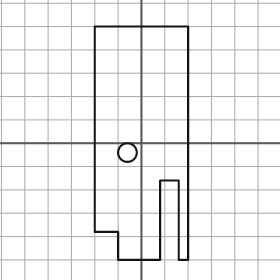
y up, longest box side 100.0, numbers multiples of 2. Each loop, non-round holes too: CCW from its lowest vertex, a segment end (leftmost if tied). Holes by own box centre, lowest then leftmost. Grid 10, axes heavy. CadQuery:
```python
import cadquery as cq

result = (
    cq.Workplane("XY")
    .moveTo(-10.0, -50.0)
    .lineTo(8.0, -50.0)
    .lineTo(8.0, -16.0)
    .lineTo(16.0, -16.0)
    .lineTo(16.0, -50.0)
    .lineTo(20.0, -50.0)
    .lineTo(20.0, 50.0)
    .lineTo(-20.0, 50.0)
    .lineTo(-20.0, -38.0)
    .lineTo(-10.0, -38.0)
    .close()
    .moveTo(-6.0, -4.0)
    .circle(4.0)
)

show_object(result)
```